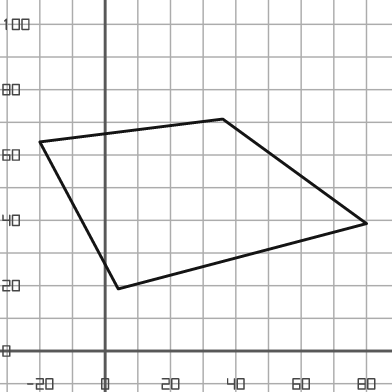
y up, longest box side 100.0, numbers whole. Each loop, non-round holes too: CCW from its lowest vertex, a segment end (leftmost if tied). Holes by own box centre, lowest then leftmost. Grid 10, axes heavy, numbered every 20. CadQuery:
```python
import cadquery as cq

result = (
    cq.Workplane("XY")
    .moveTo(4.0, 19.0)
    .lineTo(80.0, 39.0)
    .lineTo(36.0, 71.0)
    .lineTo(-20.0, 64.0)
    .close()
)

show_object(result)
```